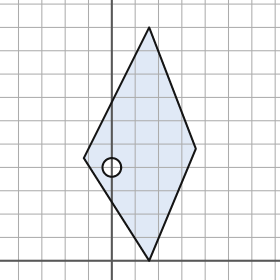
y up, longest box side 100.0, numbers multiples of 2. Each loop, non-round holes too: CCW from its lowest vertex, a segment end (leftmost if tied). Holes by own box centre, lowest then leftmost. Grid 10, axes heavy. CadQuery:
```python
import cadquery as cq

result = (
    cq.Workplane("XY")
    .moveTo(16.0, 0.0)
    .lineTo(36.0, 48.0)
    .lineTo(16.0, 100.0)
    .lineTo(-12.0, 44.0)
    .close()
    .moveTo(0.0, 40.0)
    .circle(4.0)
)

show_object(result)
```